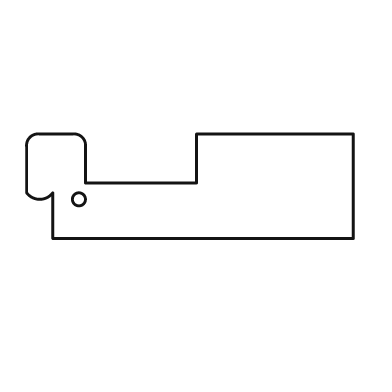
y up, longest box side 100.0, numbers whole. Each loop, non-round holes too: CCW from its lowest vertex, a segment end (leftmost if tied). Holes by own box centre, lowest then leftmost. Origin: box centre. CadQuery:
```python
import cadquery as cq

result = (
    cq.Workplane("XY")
    .moveTo(-42.0, -16.0)
    .lineTo(50.0, -16.0)
    .lineTo(50.0, 16.0)
    .lineTo(2.0, 16.0)
    .lineTo(2.0, 1.0)
    .lineTo(-32.0, 1.0)
    .lineTo(-32.0, 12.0)
    .threePointArc((-33.0, 15.0), (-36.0, 16.0))
    .lineTo(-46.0, 16.0)
    .threePointArc((-49.0, 15.0), (-50.0, 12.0))
    .lineTo(-50.0, -2.0)
    .threePointArc((-46.0, -4.0), (-42.0, -2.0))
    .close()
    .moveTo(-34.0, -4.0)
    .circle(2.0)
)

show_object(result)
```